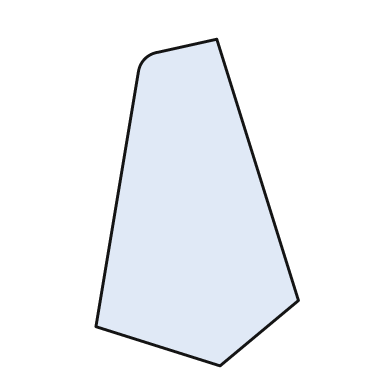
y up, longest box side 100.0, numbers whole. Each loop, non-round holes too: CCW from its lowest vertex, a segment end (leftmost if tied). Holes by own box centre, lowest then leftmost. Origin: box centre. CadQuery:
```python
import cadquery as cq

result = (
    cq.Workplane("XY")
    .moveTo(7.0, -50.0)
    .lineTo(31.0, -30.0)
    .lineTo(6.0, 50.0)
    .lineTo(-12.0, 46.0)
    .threePointArc((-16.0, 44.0), (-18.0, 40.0))
    .lineTo(-31.0, -38.0)
    .close()
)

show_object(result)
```